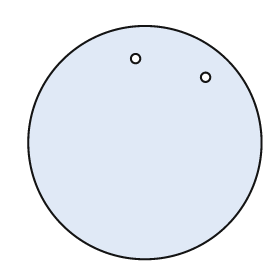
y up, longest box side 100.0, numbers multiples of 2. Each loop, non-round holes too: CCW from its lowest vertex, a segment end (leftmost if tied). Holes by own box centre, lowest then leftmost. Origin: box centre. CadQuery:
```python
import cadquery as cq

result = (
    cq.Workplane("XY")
    .moveTo(0.0, 0.0)
    .circle(50.0)
    .moveTo(26.0, 28.0)
    .circle(2.0)
    .moveTo(-4.0, 36.0)
    .circle(2.0)
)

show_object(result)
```